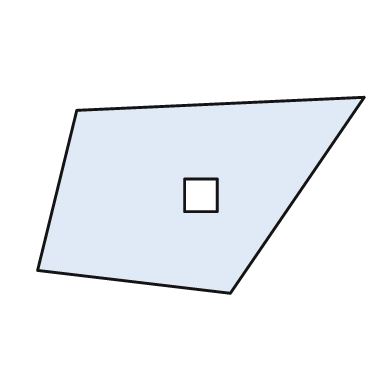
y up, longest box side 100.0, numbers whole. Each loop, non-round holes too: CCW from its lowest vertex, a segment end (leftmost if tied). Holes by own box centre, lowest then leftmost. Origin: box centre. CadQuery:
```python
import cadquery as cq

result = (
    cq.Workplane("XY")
    .moveTo(9.0, -30.0)
    .lineTo(50.0, 30.0)
    .lineTo(-38.0, 26.0)
    .lineTo(-50.0, -23.0)
    .close()
    .moveTo(-5.0, -5.0)
    .lineTo(5.0, -5.0)
    .lineTo(5.0, 5.0)
    .lineTo(-5.0, 5.0)
    .close()
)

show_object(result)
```